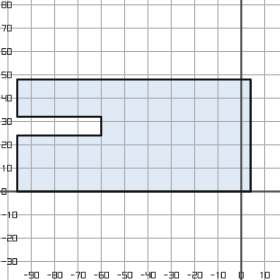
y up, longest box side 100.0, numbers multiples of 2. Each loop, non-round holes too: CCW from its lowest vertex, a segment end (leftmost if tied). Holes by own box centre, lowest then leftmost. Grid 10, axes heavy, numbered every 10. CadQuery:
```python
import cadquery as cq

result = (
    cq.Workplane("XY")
    .moveTo(-96.0, 0.0)
    .lineTo(4.0, 0.0)
    .lineTo(4.0, 48.0)
    .lineTo(-96.0, 48.0)
    .lineTo(-96.0, 32.0)
    .lineTo(-60.0, 32.0)
    .lineTo(-60.0, 24.0)
    .lineTo(-96.0, 24.0)
    .close()
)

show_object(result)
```